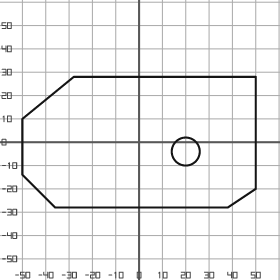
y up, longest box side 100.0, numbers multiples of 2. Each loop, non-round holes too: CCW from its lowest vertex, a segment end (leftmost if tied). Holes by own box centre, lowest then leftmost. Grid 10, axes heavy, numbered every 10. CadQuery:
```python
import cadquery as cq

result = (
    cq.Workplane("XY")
    .moveTo(-36.0, -28.0)
    .lineTo(38.0, -28.0)
    .lineTo(50.0, -20.0)
    .lineTo(50.0, 28.0)
    .lineTo(-28.0, 28.0)
    .lineTo(-50.0, 10.0)
    .lineTo(-50.0, -14.0)
    .close()
    .moveTo(20.0, -4.0)
    .circle(6.0)
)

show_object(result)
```